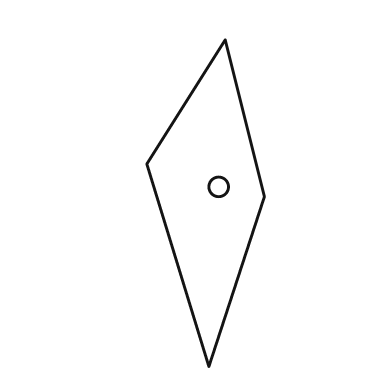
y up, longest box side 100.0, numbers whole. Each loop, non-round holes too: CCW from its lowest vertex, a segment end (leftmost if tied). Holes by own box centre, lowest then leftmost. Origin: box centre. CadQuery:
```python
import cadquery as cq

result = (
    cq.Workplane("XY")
    .moveTo(1.0, -50.0)
    .lineTo(18.0, 2.0)
    .lineTo(6.0, 50.0)
    .lineTo(-18.0, 12.0)
    .close()
    .moveTo(4.0, 5.0)
    .circle(3.0)
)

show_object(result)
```